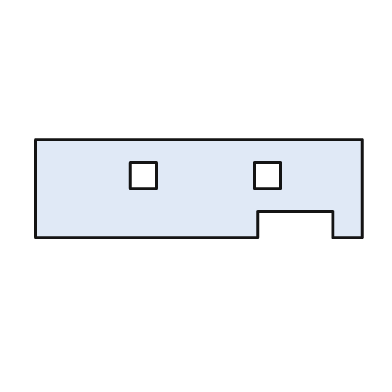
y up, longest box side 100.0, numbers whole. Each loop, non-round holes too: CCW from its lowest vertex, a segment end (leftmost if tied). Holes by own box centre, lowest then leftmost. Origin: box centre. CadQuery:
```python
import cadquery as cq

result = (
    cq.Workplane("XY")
    .moveTo(-50.0, -15.0)
    .lineTo(18.0, -15.0)
    .lineTo(18.0, -7.0)
    .lineTo(41.0, -7.0)
    .lineTo(41.0, -15.0)
    .lineTo(50.0, -15.0)
    .lineTo(50.0, 15.0)
    .lineTo(-50.0, 15.0)
    .close()
    .moveTo(-21.0, 0.0)
    .lineTo(-13.0, 0.0)
    .lineTo(-13.0, 8.0)
    .lineTo(-21.0, 8.0)
    .close()
    .moveTo(17.0, 0.0)
    .lineTo(25.0, 0.0)
    .lineTo(25.0, 8.0)
    .lineTo(17.0, 8.0)
    .close()
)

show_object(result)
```